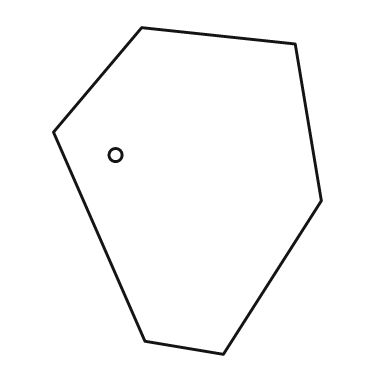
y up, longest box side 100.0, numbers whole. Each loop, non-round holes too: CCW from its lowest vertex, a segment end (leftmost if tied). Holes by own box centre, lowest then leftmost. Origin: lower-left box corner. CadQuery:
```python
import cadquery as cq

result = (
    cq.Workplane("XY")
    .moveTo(52.0, 0.0)
    .lineTo(82.0, 47.0)
    .lineTo(74.0, 95.0)
    .lineTo(27.0, 100.0)
    .lineTo(0.0, 68.0)
    .lineTo(28.0, 4.0)
    .close()
    .moveTo(19.0, 61.0)
    .circle(2.0)
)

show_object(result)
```